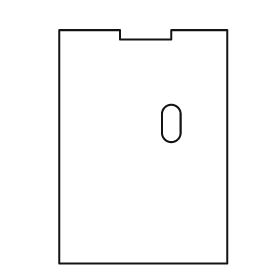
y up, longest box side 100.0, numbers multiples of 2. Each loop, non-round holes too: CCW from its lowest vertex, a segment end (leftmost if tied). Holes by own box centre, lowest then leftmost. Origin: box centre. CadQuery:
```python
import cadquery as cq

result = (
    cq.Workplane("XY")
    .moveTo(-36.0, -50.0)
    .lineTo(36.0, -50.0)
    .lineTo(36.0, 50.0)
    .lineTo(12.0, 50.0)
    .lineTo(12.0, 46.0)
    .lineTo(-10.0, 46.0)
    .lineTo(-10.0, 50.0)
    .lineTo(-36.0, 50.0)
    .close()
    .moveTo(8.0, 6.0)
    .threePointArc((12.0, 2.0), (16.0, 6.0))
    .lineTo(16.0, 14.0)
    .threePointArc((12.0, 18.0), (8.0, 14.0))
    .close()
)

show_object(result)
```